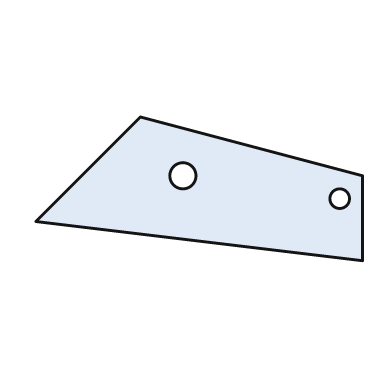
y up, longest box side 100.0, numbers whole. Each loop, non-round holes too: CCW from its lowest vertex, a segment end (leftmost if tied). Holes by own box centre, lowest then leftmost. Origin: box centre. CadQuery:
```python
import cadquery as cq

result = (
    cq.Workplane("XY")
    .moveTo(50.0, -22.0)
    .lineTo(50.0, 4.0)
    .lineTo(-18.0, 22.0)
    .lineTo(-50.0, -10.0)
    .close()
    .moveTo(43.0, -3.0)
    .circle(3.0)
    .moveTo(-5.0, 4.0)
    .circle(4.0)
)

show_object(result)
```